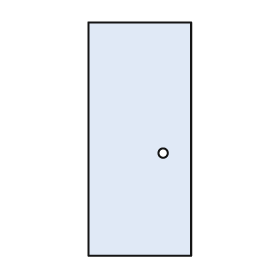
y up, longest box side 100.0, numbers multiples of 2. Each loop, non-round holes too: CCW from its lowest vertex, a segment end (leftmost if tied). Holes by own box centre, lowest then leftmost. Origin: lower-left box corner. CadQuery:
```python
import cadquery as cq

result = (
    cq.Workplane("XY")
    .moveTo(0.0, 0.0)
    .lineTo(44.0, 0.0)
    .lineTo(44.0, 100.0)
    .lineTo(0.0, 100.0)
    .close()
    .moveTo(32.0, 44.0)
    .circle(2.0)
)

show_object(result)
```